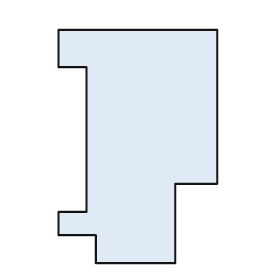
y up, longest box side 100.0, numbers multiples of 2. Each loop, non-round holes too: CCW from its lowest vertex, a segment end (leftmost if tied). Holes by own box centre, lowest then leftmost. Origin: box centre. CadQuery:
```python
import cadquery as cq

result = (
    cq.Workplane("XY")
    .moveTo(-18.0, -50.0)
    .lineTo(16.0, -50.0)
    .lineTo(16.0, -16.0)
    .lineTo(34.0, -16.0)
    .lineTo(34.0, 50.0)
    .lineTo(-34.0, 50.0)
    .lineTo(-34.0, 34.0)
    .lineTo(-22.0, 34.0)
    .lineTo(-22.0, -28.0)
    .lineTo(-34.0, -28.0)
    .lineTo(-34.0, -38.0)
    .lineTo(-18.0, -38.0)
    .close()
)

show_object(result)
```